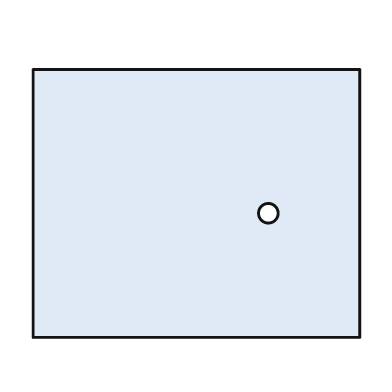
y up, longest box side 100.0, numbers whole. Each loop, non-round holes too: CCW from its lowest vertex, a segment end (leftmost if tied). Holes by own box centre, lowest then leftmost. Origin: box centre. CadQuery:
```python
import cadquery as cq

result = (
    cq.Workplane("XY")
    .moveTo(-50.0, -41.0)
    .lineTo(50.0, -41.0)
    .lineTo(50.0, 41.0)
    .lineTo(-50.0, 41.0)
    .close()
    .moveTo(22.0, -3.0)
    .circle(3.0)
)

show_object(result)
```